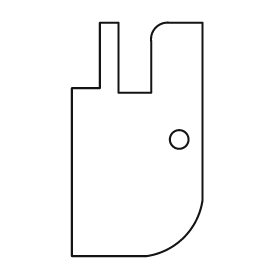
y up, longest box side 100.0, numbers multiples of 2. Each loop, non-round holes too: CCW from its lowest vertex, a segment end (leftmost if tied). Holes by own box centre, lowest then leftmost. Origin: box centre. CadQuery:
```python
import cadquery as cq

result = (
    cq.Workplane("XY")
    .moveTo(-28.0, -50.0)
    .lineTo(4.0, -50.0)
    .threePointArc((20.0, -42.0), (28.0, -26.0))
    .lineTo(28.0, 50.0)
    .lineTo(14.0, 50.0)
    .threePointArc((8.0, 48.0), (6.0, 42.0))
    .lineTo(6.0, 20.0)
    .lineTo(-8.0, 20.0)
    .lineTo(-8.0, 50.0)
    .lineTo(-16.0, 50.0)
    .lineTo(-16.0, 22.0)
    .lineTo(-28.0, 22.0)
    .close()
    .moveTo(18.0, 0.0)
    .circle(4.0)
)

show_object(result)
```